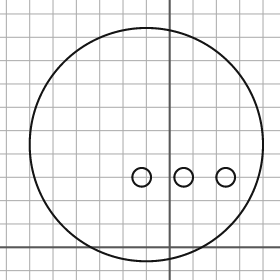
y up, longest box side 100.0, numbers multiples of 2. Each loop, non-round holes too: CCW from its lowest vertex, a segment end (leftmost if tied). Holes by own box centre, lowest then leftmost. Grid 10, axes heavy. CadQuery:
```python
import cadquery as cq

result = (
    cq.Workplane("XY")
    .moveTo(-10.0, 44.0)
    .circle(50.0)
    .moveTo(-12.0, 30.0)
    .circle(4.0)
    .moveTo(6.0, 30.0)
    .circle(4.0)
    .moveTo(24.0, 30.0)
    .circle(4.0)
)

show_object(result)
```